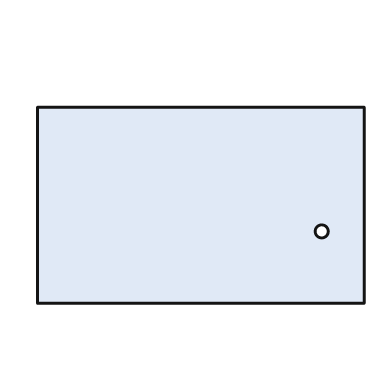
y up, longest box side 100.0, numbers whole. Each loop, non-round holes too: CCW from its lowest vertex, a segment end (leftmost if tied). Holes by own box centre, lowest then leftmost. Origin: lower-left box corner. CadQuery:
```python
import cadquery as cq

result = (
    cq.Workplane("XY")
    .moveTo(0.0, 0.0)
    .lineTo(100.0, 0.0)
    .lineTo(100.0, 60.0)
    .lineTo(0.0, 60.0)
    .close()
    .moveTo(87.0, 22.0)
    .circle(2.0)
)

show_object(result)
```